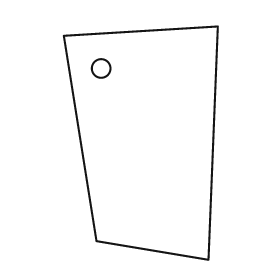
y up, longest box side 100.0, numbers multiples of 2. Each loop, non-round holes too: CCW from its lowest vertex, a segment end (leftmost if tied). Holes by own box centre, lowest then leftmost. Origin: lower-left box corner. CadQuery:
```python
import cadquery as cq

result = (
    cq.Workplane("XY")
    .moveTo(62.0, 0.0)
    .lineTo(66.0, 100.0)
    .lineTo(0.0, 96.0)
    .lineTo(14.0, 8.0)
    .close()
    .moveTo(16.0, 82.0)
    .circle(4.0)
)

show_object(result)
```